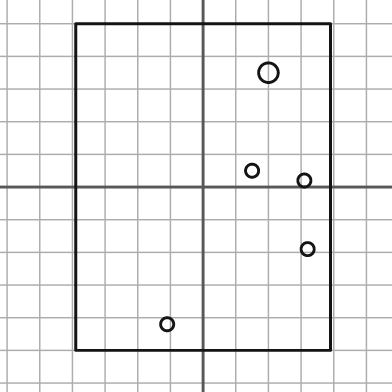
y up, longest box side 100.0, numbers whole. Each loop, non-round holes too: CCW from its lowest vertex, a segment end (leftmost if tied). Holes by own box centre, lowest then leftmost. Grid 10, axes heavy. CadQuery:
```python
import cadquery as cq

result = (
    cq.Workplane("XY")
    .moveTo(-39.0, -50.0)
    .lineTo(39.0, -50.0)
    .lineTo(39.0, 50.0)
    .lineTo(-39.0, 50.0)
    .close()
    .moveTo(-11.0, -42.0)
    .circle(2.0)
    .moveTo(32.0, -19.0)
    .circle(2.0)
    .moveTo(31.0, 2.0)
    .circle(2.0)
    .moveTo(15.0, 5.0)
    .circle(2.0)
    .moveTo(20.0, 35.0)
    .circle(3.0)
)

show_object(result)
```